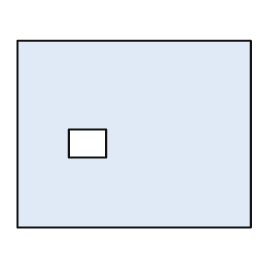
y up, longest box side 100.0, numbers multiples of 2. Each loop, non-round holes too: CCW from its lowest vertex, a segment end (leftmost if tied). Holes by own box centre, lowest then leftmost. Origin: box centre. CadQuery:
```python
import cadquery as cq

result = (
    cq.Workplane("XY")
    .moveTo(-50.0, -40.0)
    .lineTo(50.0, -40.0)
    .lineTo(50.0, 40.0)
    .lineTo(-50.0, 40.0)
    .close()
    .moveTo(-28.0, -10.0)
    .lineTo(-12.0, -10.0)
    .lineTo(-12.0, 2.0)
    .lineTo(-28.0, 2.0)
    .close()
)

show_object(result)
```